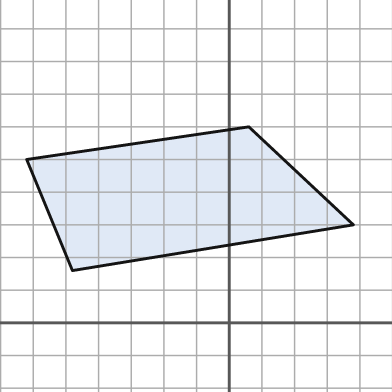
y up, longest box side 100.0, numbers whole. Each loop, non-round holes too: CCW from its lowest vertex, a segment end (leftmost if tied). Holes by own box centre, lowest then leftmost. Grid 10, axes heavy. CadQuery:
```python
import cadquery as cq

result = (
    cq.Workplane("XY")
    .moveTo(-48.0, 16.0)
    .lineTo(38.0, 30.0)
    .lineTo(6.0, 60.0)
    .lineTo(-62.0, 50.0)
    .close()
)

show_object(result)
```